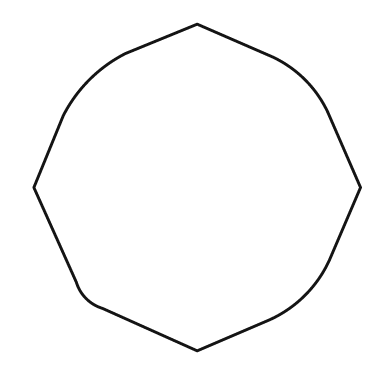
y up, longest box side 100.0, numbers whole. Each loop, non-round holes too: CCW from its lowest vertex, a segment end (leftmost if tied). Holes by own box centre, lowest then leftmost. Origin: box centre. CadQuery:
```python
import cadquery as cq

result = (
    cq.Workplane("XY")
    .moveTo(0.0, -50.0)
    .lineTo(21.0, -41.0)
    .threePointArc((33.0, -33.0), (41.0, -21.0))
    .lineTo(50.0, 0.0)
    .lineTo(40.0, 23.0)
    .threePointArc((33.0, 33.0), (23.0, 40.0))
    .lineTo(0.0, 50.0)
    .lineTo(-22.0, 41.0)
    .threePointArc((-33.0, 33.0), (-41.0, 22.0))
    .lineTo(-50.0, 0.0)
    .lineTo(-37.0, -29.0)
    .threePointArc((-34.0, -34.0), (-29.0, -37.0))
    .close()
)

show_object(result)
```